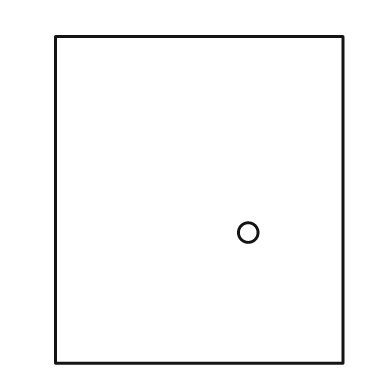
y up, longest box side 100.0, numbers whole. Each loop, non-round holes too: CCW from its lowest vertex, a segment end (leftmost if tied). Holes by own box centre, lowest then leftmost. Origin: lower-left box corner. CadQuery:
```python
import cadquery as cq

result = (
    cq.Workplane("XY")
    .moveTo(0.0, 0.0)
    .lineTo(88.0, 0.0)
    .lineTo(88.0, 100.0)
    .lineTo(0.0, 100.0)
    .close()
    .moveTo(59.0, 40.0)
    .circle(3.0)
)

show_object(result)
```